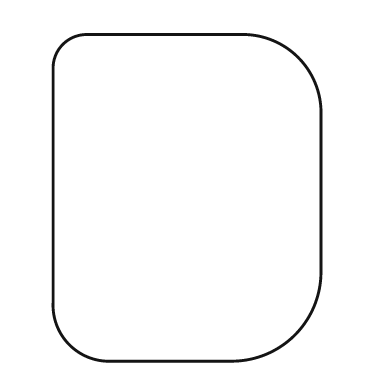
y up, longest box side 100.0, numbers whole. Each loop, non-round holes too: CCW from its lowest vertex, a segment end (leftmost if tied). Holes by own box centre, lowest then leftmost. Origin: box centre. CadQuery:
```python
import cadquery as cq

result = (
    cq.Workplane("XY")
    .moveTo(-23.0, -50.0)
    .lineTo(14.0, -50.0)
    .threePointArc((33.0, -42.0), (41.0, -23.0))
    .lineTo(41.0, 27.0)
    .threePointArc((34.0, 43.0), (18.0, 50.0))
    .lineTo(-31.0, 50.0)
    .threePointArc((-38.0, 47.0), (-41.0, 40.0))
    .lineTo(-41.0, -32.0)
    .threePointArc((-36.0, -45.0), (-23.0, -50.0))
    .close()
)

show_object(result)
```